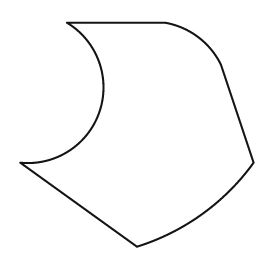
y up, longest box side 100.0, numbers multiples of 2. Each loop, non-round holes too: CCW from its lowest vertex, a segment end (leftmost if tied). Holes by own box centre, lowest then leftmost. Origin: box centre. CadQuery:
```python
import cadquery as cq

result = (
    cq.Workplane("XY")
    .moveTo(0.0, -48.0)
    .threePointArc((28.0, -34.0), (50.0, -12.0))
    .lineTo(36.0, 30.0)
    .threePointArc((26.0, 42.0), (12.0, 48.0))
    .lineTo(-30.0, 48.0)
    .threePointArc((-16.0, 10.0), (-50.0, -12.0))
    .close()
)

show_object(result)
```